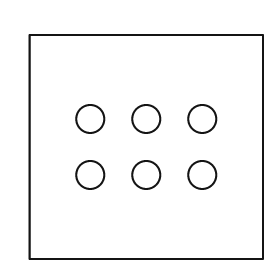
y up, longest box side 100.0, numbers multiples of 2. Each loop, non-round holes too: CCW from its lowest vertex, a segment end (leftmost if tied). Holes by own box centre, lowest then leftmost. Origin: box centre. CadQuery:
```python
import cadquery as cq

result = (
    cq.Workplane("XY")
    .moveTo(-50.0, -48.0)
    .lineTo(50.0, -48.0)
    .lineTo(50.0, 48.0)
    .lineTo(-50.0, 48.0)
    .close()
    .moveTo(-24.0, -12.0)
    .circle(6.0)
    .moveTo(0.0, -12.0)
    .circle(6.0)
    .moveTo(24.0, -12.0)
    .circle(6.0)
    .moveTo(-24.0, 12.0)
    .circle(6.0)
    .moveTo(0.0, 12.0)
    .circle(6.0)
    .moveTo(24.0, 12.0)
    .circle(6.0)
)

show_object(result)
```